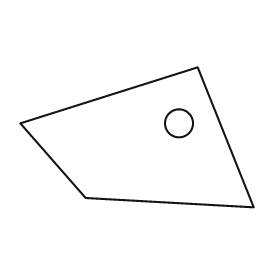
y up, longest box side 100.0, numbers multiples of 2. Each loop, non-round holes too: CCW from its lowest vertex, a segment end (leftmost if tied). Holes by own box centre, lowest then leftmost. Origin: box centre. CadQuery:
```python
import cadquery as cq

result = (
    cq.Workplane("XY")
    .moveTo(50.0, -30.0)
    .lineTo(26.0, 30.0)
    .lineTo(-50.0, 6.0)
    .lineTo(-22.0, -26.0)
    .close()
    .moveTo(18.0, 6.0)
    .circle(6.0)
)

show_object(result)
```